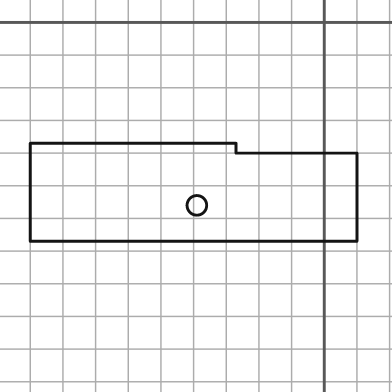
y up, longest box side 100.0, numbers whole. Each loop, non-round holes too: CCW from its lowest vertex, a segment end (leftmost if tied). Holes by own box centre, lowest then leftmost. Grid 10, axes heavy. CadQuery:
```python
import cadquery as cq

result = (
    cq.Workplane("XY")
    .moveTo(-90.0, -67.0)
    .lineTo(10.0, -67.0)
    .lineTo(10.0, -40.0)
    .lineTo(-27.0, -40.0)
    .lineTo(-27.0, -37.0)
    .lineTo(-90.0, -37.0)
    .close()
    .moveTo(-39.0, -56.0)
    .circle(3.0)
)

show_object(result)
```